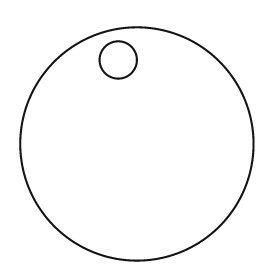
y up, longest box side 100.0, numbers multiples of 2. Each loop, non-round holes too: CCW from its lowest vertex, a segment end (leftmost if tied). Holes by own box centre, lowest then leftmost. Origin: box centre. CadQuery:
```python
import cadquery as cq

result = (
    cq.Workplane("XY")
    .moveTo(0.0, 0.0)
    .circle(50.0)
    .moveTo(-8.0, 36.0)
    .circle(8.0)
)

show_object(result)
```